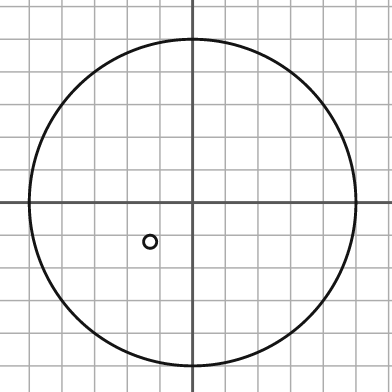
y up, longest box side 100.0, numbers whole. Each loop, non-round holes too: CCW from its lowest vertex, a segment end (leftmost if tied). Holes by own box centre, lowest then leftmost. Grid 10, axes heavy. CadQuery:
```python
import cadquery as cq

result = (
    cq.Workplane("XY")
    .moveTo(0.0, 0.0)
    .circle(50.0)
    .moveTo(-13.0, -12.0)
    .circle(2.0)
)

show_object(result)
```